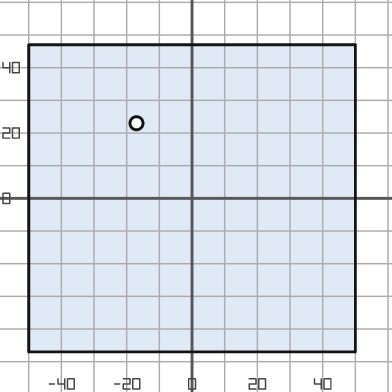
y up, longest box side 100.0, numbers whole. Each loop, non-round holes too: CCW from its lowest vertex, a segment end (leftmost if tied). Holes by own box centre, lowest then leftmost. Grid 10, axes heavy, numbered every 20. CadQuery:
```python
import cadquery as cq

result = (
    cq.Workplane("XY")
    .moveTo(-50.0, -47.0)
    .lineTo(50.0, -47.0)
    .lineTo(50.0, 47.0)
    .lineTo(-50.0, 47.0)
    .close()
    .moveTo(-17.0, 23.0)
    .circle(2.0)
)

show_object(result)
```